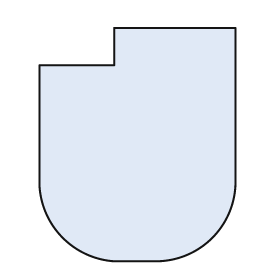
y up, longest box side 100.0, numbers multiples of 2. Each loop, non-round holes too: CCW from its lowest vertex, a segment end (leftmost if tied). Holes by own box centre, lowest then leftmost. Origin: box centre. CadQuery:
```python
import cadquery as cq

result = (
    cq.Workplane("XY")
    .moveTo(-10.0, -50.0)
    .lineTo(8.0, -50.0)
    .threePointArc((32.0, -40.0), (42.0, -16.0))
    .lineTo(42.0, 50.0)
    .lineTo(-10.0, 50.0)
    .lineTo(-10.0, 34.0)
    .lineTo(-42.0, 34.0)
    .lineTo(-42.0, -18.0)
    .threePointArc((-32.0, -40.0), (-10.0, -50.0))
    .close()
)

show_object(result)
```